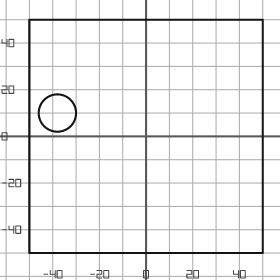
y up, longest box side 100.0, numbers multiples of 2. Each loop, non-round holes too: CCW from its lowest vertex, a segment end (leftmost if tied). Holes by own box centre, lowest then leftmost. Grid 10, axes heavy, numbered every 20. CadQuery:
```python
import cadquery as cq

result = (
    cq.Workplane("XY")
    .moveTo(-50.0, -50.0)
    .lineTo(50.0, -50.0)
    .lineTo(50.0, 50.0)
    .lineTo(-50.0, 50.0)
    .close()
    .moveTo(-38.0, 10.0)
    .circle(8.0)
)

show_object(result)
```